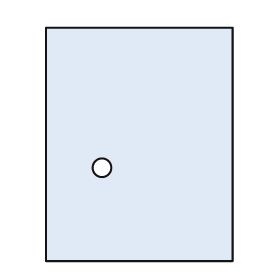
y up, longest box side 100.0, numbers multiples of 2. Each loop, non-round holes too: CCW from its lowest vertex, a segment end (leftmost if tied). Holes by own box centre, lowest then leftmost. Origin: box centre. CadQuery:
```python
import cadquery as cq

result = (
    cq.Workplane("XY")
    .moveTo(-40.0, -50.0)
    .lineTo(40.0, -50.0)
    .lineTo(40.0, 50.0)
    .lineTo(-40.0, 50.0)
    .close()
    .moveTo(-16.0, -10.0)
    .circle(4.0)
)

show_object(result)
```